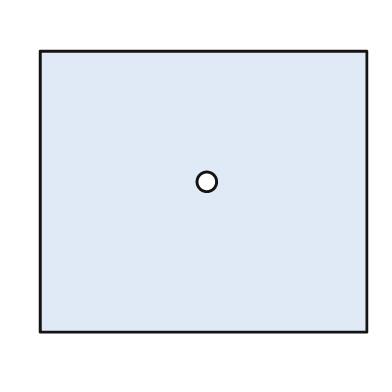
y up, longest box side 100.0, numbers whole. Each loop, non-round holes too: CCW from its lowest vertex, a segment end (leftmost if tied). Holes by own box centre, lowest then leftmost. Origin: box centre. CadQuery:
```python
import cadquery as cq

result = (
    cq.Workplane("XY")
    .moveTo(-50.0, -43.0)
    .lineTo(50.0, -43.0)
    .lineTo(50.0, 43.0)
    .lineTo(-50.0, 43.0)
    .close()
    .moveTo(1.0, 3.0)
    .circle(3.0)
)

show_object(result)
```